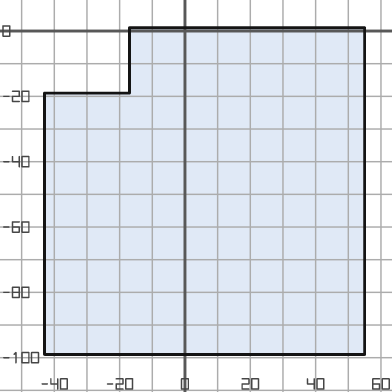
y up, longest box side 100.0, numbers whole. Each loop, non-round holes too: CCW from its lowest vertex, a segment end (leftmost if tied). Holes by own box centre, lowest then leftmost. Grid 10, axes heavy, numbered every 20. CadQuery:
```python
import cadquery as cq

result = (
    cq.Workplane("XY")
    .moveTo(-43.0, -99.0)
    .lineTo(55.0, -99.0)
    .lineTo(55.0, 1.0)
    .lineTo(-17.0, 1.0)
    .lineTo(-17.0, -19.0)
    .lineTo(-43.0, -19.0)
    .close()
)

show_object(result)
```